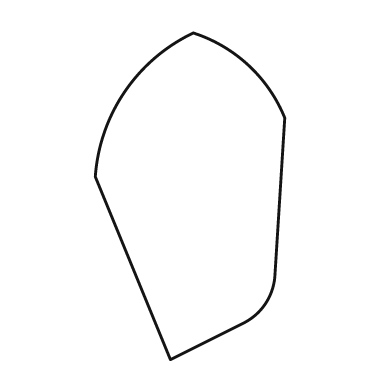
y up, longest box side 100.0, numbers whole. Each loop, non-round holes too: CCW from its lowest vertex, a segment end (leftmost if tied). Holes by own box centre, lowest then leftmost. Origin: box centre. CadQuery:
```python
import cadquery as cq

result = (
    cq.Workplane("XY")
    .moveTo(-6.0, -50.0)
    .lineTo(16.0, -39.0)
    .threePointArc((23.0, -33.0), (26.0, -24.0))
    .lineTo(29.0, 24.0)
    .threePointArc((18.0, 40.0), (1.0, 50.0))
    .threePointArc((-20.0, 32.0), (-29.0, 6.0))
    .close()
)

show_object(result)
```